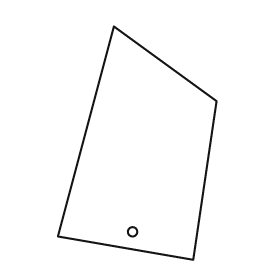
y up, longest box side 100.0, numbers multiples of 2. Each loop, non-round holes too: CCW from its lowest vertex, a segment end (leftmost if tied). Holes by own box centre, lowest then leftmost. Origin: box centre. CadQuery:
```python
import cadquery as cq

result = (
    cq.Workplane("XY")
    .moveTo(24.0, -50.0)
    .lineTo(34.0, 18.0)
    .lineTo(-10.0, 50.0)
    .lineTo(-34.0, -40.0)
    .close()
    .moveTo(-2.0, -38.0)
    .circle(2.0)
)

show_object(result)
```